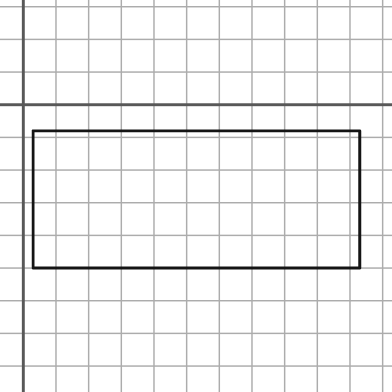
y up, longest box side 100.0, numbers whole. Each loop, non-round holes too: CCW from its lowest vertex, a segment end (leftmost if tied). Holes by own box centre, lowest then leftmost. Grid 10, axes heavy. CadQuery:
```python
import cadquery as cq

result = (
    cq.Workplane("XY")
    .moveTo(3.0, -50.0)
    .lineTo(103.0, -50.0)
    .lineTo(103.0, -8.0)
    .lineTo(3.0, -8.0)
    .close()
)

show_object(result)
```